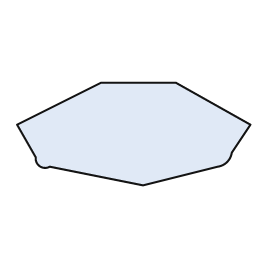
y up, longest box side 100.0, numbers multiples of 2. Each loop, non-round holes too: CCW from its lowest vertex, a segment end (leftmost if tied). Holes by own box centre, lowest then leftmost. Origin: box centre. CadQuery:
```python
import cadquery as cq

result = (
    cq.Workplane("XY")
    .moveTo(4.0, -22.0)
    .lineTo(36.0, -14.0)
    .threePointArc((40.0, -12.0), (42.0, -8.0))
    .lineTo(50.0, 4.0)
    .lineTo(18.0, 22.0)
    .lineTo(-14.0, 22.0)
    .lineTo(-50.0, 4.0)
    .lineTo(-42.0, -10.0)
    .threePointArc((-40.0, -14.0), (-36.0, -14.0))
    .close()
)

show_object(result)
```